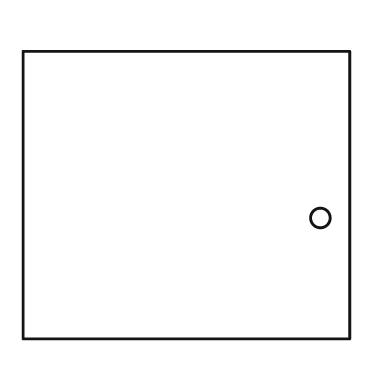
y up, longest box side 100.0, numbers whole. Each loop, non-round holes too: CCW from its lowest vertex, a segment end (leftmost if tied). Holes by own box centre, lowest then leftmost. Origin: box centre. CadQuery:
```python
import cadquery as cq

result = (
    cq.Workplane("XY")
    .moveTo(-50.0, -44.0)
    .lineTo(50.0, -44.0)
    .lineTo(50.0, 44.0)
    .lineTo(-50.0, 44.0)
    .close()
    .moveTo(41.0, -7.0)
    .circle(3.0)
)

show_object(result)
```